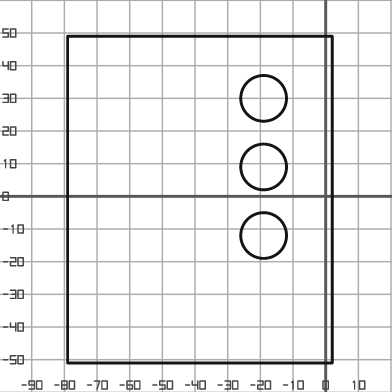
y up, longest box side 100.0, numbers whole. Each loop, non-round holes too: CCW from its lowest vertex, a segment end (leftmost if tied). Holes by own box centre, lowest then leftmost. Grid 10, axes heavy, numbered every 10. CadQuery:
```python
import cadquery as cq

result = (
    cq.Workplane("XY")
    .moveTo(-79.0, -51.0)
    .lineTo(2.0, -51.0)
    .lineTo(2.0, 49.0)
    .lineTo(-79.0, 49.0)
    .close()
    .moveTo(-19.0, -12.0)
    .circle(7.0)
    .moveTo(-19.0, 9.0)
    .circle(7.0)
    .moveTo(-19.0, 30.0)
    .circle(7.0)
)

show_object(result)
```